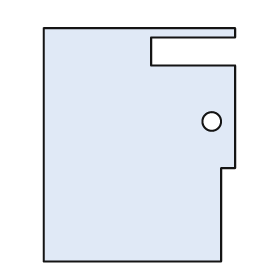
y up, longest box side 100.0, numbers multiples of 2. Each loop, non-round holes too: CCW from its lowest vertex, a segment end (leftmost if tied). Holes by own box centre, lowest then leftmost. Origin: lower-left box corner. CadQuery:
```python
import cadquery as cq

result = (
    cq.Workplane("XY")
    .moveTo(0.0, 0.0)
    .lineTo(76.0, 0.0)
    .lineTo(76.0, 40.0)
    .lineTo(82.0, 40.0)
    .lineTo(82.0, 84.0)
    .lineTo(46.0, 84.0)
    .lineTo(46.0, 96.0)
    .lineTo(82.0, 96.0)
    .lineTo(82.0, 100.0)
    .lineTo(0.0, 100.0)
    .close()
    .moveTo(72.0, 60.0)
    .circle(4.0)
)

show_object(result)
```